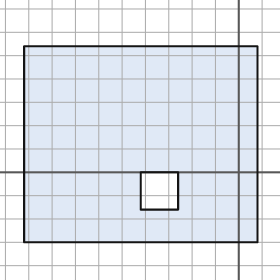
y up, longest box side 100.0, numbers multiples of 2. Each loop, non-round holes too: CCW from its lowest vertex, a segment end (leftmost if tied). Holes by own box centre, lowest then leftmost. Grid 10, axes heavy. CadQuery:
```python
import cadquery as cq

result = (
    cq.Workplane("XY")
    .moveTo(-92.0, -30.0)
    .lineTo(8.0, -30.0)
    .lineTo(8.0, 54.0)
    .lineTo(-92.0, 54.0)
    .close()
    .moveTo(-42.0, -16.0)
    .lineTo(-26.0, -16.0)
    .lineTo(-26.0, 0.0)
    .lineTo(-42.0, 0.0)
    .close()
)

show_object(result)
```